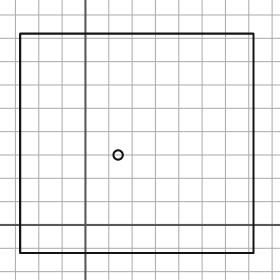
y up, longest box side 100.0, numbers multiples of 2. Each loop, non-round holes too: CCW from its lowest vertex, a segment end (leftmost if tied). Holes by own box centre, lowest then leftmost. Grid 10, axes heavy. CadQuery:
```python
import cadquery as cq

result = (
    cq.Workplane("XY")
    .moveTo(-28.0, -12.0)
    .lineTo(72.0, -12.0)
    .lineTo(72.0, 82.0)
    .lineTo(-28.0, 82.0)
    .close()
    .moveTo(14.0, 30.0)
    .circle(2.0)
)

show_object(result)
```